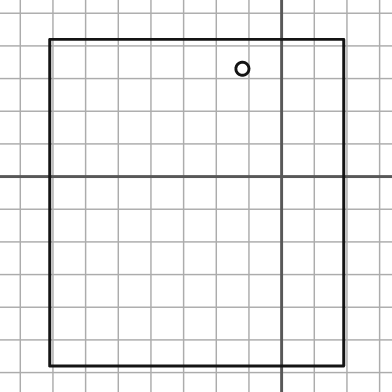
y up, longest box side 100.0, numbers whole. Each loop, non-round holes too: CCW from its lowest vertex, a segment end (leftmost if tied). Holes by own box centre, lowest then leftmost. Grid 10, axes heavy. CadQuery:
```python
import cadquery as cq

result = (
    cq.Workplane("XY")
    .moveTo(-71.0, -58.0)
    .lineTo(19.0, -58.0)
    .lineTo(19.0, 42.0)
    .lineTo(-71.0, 42.0)
    .close()
    .moveTo(-12.0, 33.0)
    .circle(2.0)
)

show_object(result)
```